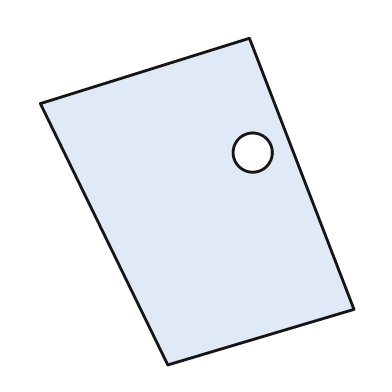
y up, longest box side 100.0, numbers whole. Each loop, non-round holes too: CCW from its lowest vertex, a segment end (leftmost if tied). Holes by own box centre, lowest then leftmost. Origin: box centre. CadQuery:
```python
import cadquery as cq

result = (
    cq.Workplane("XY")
    .moveTo(-9.0, -50.0)
    .lineTo(48.0, -33.0)
    .lineTo(16.0, 50.0)
    .lineTo(-48.0, 30.0)
    .close()
    .moveTo(17.0, 15.0)
    .circle(6.0)
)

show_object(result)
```